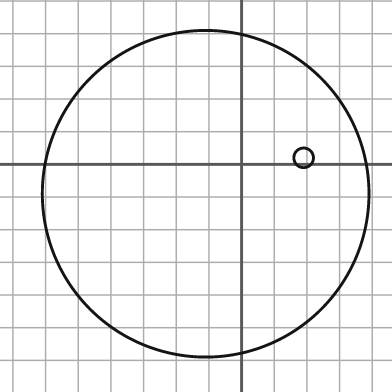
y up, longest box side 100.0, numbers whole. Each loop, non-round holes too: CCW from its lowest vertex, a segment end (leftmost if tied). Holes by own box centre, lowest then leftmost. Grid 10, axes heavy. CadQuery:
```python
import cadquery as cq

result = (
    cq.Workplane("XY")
    .moveTo(-11.0, -9.0)
    .circle(50.0)
    .moveTo(19.0, 2.0)
    .circle(3.0)
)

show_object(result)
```